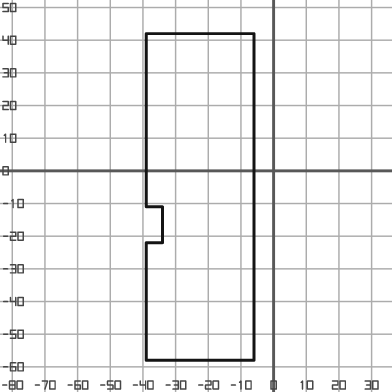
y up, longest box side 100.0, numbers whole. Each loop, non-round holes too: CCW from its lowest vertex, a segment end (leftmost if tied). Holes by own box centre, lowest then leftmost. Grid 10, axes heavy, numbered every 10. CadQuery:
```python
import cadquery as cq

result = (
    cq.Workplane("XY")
    .moveTo(-39.0, -58.0)
    .lineTo(-6.0, -58.0)
    .lineTo(-6.0, 42.0)
    .lineTo(-39.0, 42.0)
    .lineTo(-39.0, -11.0)
    .lineTo(-34.0, -11.0)
    .lineTo(-34.0, -22.0)
    .lineTo(-39.0, -22.0)
    .close()
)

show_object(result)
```